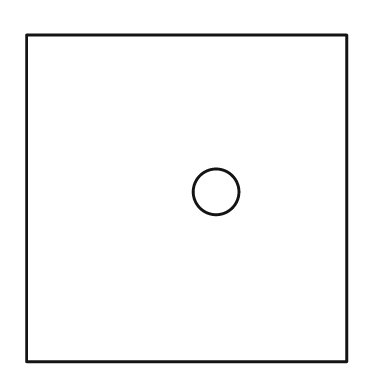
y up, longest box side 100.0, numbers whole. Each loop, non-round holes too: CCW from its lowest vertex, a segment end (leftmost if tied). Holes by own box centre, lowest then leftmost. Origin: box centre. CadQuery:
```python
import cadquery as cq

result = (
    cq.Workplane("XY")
    .moveTo(-49.0, -50.0)
    .lineTo(49.0, -50.0)
    .lineTo(49.0, 50.0)
    .lineTo(-49.0, 50.0)
    .close()
    .moveTo(9.0, 2.0)
    .circle(7.0)
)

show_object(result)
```